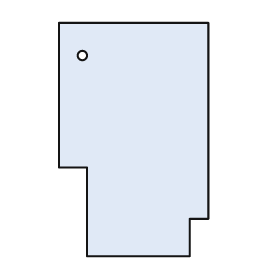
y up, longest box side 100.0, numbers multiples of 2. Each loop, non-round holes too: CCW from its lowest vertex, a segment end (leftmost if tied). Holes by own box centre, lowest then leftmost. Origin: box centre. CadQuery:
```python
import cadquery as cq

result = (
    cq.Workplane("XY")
    .moveTo(-20.0, -50.0)
    .lineTo(24.0, -50.0)
    .lineTo(24.0, -34.0)
    .lineTo(32.0, -34.0)
    .lineTo(32.0, 50.0)
    .lineTo(-32.0, 50.0)
    .lineTo(-32.0, -12.0)
    .lineTo(-20.0, -12.0)
    .close()
    .moveTo(-22.0, 36.0)
    .circle(2.0)
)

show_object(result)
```